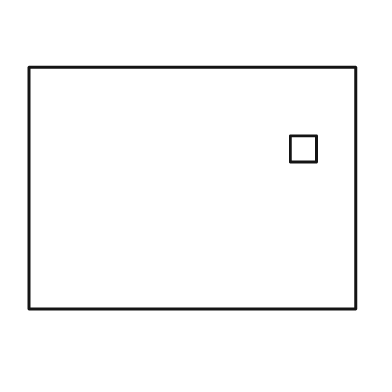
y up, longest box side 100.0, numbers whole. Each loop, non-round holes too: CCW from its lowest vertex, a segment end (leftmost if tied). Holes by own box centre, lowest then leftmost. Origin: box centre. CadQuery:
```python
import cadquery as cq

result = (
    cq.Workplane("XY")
    .moveTo(-50.0, -37.0)
    .lineTo(50.0, -37.0)
    .lineTo(50.0, 37.0)
    .lineTo(-50.0, 37.0)
    .close()
    .moveTo(30.0, 8.0)
    .lineTo(38.0, 8.0)
    .lineTo(38.0, 16.0)
    .lineTo(30.0, 16.0)
    .close()
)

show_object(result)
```